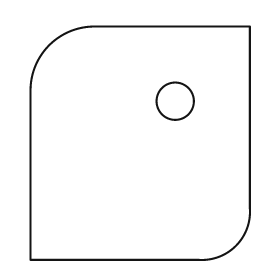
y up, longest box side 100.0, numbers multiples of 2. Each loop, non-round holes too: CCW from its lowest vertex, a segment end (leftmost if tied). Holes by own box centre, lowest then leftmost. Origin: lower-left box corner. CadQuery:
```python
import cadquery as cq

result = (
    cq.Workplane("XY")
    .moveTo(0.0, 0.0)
    .lineTo(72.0, 0.0)
    .threePointArc((88.0, 6.0), (94.0, 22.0))
    .lineTo(94.0, 100.0)
    .lineTo(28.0, 100.0)
    .threePointArc((8.0, 92.0), (0.0, 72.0))
    .close()
    .moveTo(62.0, 68.0)
    .circle(8.0)
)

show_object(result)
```